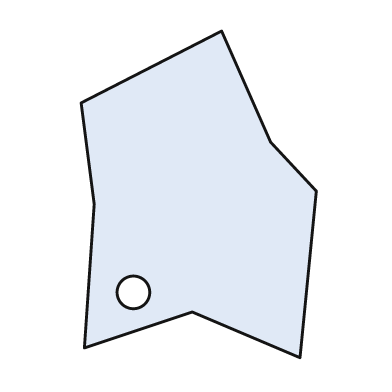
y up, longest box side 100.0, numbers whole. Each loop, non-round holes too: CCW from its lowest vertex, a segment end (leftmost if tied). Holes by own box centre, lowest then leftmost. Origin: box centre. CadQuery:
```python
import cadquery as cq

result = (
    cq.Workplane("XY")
    .moveTo(31.0, -50.0)
    .lineTo(36.0, 1.0)
    .lineTo(22.0, 16.0)
    .lineTo(7.0, 50.0)
    .lineTo(-36.0, 28.0)
    .lineTo(-32.0, -3.0)
    .lineTo(-35.0, -47.0)
    .lineTo(-2.0, -36.0)
    .close()
    .moveTo(-20.0, -30.0)
    .circle(5.0)
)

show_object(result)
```